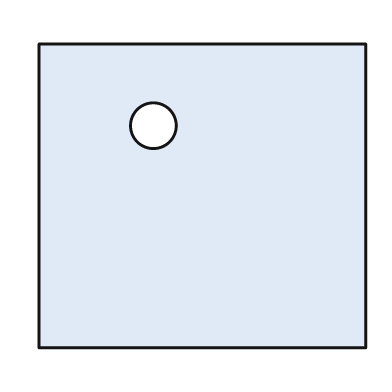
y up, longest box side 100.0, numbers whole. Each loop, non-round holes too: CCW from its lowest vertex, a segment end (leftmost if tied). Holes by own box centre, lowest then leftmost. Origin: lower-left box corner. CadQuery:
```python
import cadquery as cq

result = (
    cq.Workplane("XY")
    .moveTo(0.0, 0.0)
    .lineTo(100.0, 0.0)
    .lineTo(100.0, 93.0)
    .lineTo(0.0, 93.0)
    .close()
    .moveTo(35.0, 68.0)
    .circle(7.0)
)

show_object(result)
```